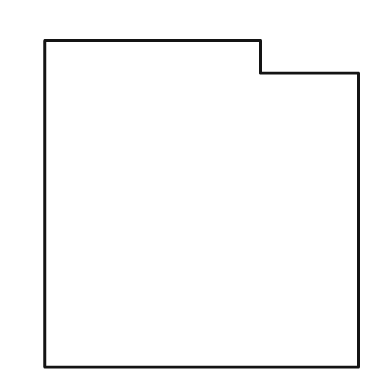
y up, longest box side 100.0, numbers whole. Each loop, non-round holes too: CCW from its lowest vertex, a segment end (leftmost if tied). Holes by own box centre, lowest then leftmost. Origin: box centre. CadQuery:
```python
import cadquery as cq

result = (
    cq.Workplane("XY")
    .moveTo(-48.0, -50.0)
    .lineTo(48.0, -50.0)
    .lineTo(48.0, 40.0)
    .lineTo(18.0, 40.0)
    .lineTo(18.0, 50.0)
    .lineTo(-48.0, 50.0)
    .close()
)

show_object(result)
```